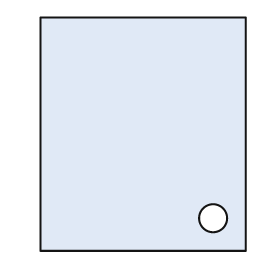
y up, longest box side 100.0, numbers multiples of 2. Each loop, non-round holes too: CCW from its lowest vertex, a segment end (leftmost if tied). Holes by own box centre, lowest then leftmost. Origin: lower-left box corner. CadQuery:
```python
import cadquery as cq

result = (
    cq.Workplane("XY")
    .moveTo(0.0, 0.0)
    .lineTo(88.0, 0.0)
    .lineTo(88.0, 100.0)
    .lineTo(0.0, 100.0)
    .close()
    .moveTo(74.0, 14.0)
    .circle(6.0)
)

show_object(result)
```